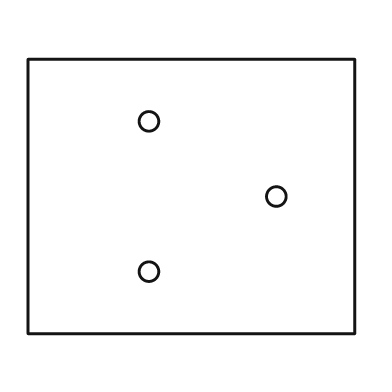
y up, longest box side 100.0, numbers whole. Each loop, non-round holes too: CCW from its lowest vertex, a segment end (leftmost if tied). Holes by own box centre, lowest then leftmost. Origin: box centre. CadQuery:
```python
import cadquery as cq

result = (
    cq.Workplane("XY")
    .moveTo(-50.0, -42.0)
    .lineTo(50.0, -42.0)
    .lineTo(50.0, 42.0)
    .lineTo(-50.0, 42.0)
    .close()
    .moveTo(-13.0, -23.0)
    .circle(3.0)
    .moveTo(26.0, 0.0)
    .circle(3.0)
    .moveTo(-13.0, 23.0)
    .circle(3.0)
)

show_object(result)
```